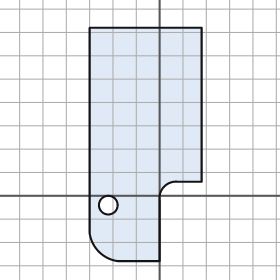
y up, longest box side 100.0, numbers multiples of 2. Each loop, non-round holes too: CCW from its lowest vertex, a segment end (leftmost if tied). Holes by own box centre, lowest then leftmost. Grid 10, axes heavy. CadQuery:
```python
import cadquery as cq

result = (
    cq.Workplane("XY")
    .moveTo(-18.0, -28.0)
    .lineTo(0.0, -28.0)
    .lineTo(0.0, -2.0)
    .threePointArc((2.0, 4.0), (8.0, 6.0))
    .lineTo(18.0, 6.0)
    .lineTo(18.0, 72.0)
    .lineTo(-30.0, 72.0)
    .lineTo(-30.0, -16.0)
    .threePointArc((-26.0, -24.0), (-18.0, -28.0))
    .close()
    .moveTo(-22.0, -4.0)
    .circle(4.0)
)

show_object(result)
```